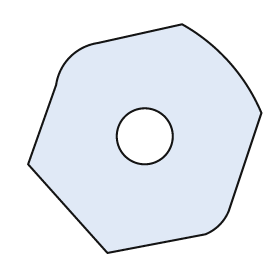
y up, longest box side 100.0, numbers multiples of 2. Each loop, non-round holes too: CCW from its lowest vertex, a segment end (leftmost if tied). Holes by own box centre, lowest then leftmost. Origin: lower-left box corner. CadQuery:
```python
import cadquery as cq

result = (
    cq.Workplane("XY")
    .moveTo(34.0, 0.0)
    .lineTo(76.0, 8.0)
    .threePointArc((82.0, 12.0), (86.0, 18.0))
    .lineTo(100.0, 60.0)
    .threePointArc((86.0, 82.0), (66.0, 98.0))
    .lineTo(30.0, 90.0)
    .threePointArc((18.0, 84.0), (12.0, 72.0))
    .lineTo(0.0, 38.0)
    .close()
    .moveTo(50.0, 50.0)
    .circle(12.0)
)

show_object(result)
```